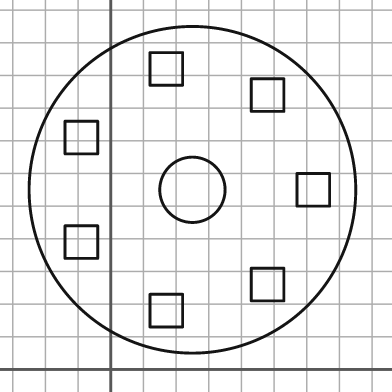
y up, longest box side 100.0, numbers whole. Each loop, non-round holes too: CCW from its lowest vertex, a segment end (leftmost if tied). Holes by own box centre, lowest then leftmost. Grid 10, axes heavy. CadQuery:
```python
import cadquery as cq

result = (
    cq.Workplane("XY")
    .moveTo(25.0, 55.0)
    .circle(50.0)
    .moveTo(12.0, 13.0)
    .lineTo(22.0, 13.0)
    .lineTo(22.0, 23.0)
    .lineTo(12.0, 23.0)
    .close()
    .moveTo(43.0, 21.0)
    .lineTo(53.0, 21.0)
    .lineTo(53.0, 31.0)
    .lineTo(43.0, 31.0)
    .close()
    .moveTo(-14.0, 34.0)
    .lineTo(-4.0, 34.0)
    .lineTo(-4.0, 44.0)
    .lineTo(-14.0, 44.0)
    .close()
    .moveTo(25.0, 55.0)
    .circle(10.0)
    .moveTo(57.0, 50.0)
    .lineTo(67.0, 50.0)
    .lineTo(67.0, 60.0)
    .lineTo(57.0, 60.0)
    .close()
    .moveTo(-14.0, 66.0)
    .lineTo(-4.0, 66.0)
    .lineTo(-4.0, 76.0)
    .lineTo(-14.0, 76.0)
    .close()
    .moveTo(43.0, 79.0)
    .lineTo(53.0, 79.0)
    .lineTo(53.0, 89.0)
    .lineTo(43.0, 89.0)
    .close()
    .moveTo(12.0, 87.0)
    .lineTo(22.0, 87.0)
    .lineTo(22.0, 97.0)
    .lineTo(12.0, 97.0)
    .close()
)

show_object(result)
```